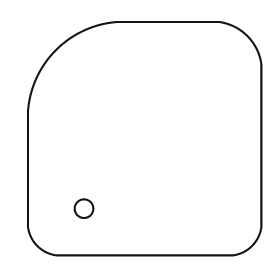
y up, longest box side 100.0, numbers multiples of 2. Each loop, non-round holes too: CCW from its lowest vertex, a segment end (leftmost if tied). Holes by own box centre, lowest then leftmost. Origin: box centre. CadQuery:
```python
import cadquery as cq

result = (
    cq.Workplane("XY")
    .moveTo(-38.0, -50.0)
    .lineTo(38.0, -50.0)
    .threePointArc((46.0, -46.0), (50.0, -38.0))
    .lineTo(50.0, 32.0)
    .threePointArc((44.0, 44.0), (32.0, 50.0))
    .lineTo(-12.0, 50.0)
    .threePointArc((-38.0, 38.0), (-50.0, 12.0))
    .lineTo(-50.0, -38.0)
    .threePointArc((-46.0, -46.0), (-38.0, -50.0))
    .close()
    .moveTo(-26.0, -30.0)
    .circle(4.0)
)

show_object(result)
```